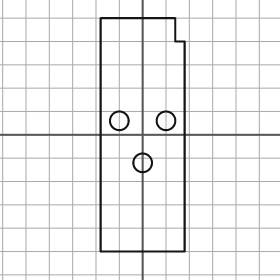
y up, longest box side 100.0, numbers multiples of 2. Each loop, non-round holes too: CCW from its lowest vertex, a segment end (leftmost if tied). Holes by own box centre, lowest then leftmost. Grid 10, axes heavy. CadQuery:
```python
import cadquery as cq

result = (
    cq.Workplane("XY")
    .moveTo(-18.0, -50.0)
    .lineTo(18.0, -50.0)
    .lineTo(18.0, 40.0)
    .lineTo(14.0, 40.0)
    .lineTo(14.0, 50.0)
    .lineTo(-18.0, 50.0)
    .close()
    .moveTo(0.0, -12.0)
    .circle(4.0)
    .moveTo(-10.0, 6.0)
    .circle(4.0)
    .moveTo(10.0, 6.0)
    .circle(4.0)
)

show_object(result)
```